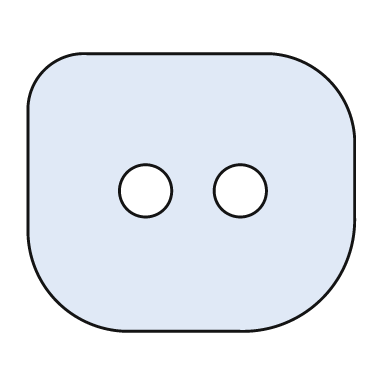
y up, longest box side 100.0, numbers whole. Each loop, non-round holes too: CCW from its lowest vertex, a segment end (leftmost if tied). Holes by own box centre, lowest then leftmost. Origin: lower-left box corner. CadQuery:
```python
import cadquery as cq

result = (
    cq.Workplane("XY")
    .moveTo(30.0, 0.0)
    .lineTo(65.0, 0.0)
    .threePointArc((90.0, 10.0), (100.0, 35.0))
    .lineTo(100.0, 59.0)
    .threePointArc((92.0, 77.0), (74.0, 85.0))
    .lineTo(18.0, 85.0)
    .threePointArc((5.0, 80.0), (0.0, 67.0))
    .lineTo(0.0, 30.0)
    .threePointArc((9.0, 9.0), (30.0, 0.0))
    .close()
    .moveTo(36.0, 43.0)
    .circle(8.0)
    .moveTo(65.0, 43.0)
    .circle(8.0)
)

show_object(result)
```